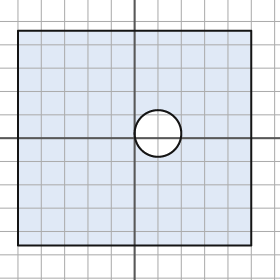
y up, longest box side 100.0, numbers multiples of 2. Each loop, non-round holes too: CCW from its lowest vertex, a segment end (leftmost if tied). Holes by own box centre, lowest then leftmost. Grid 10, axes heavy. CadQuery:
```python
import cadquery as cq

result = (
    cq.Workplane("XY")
    .moveTo(-50.0, -46.0)
    .lineTo(50.0, -46.0)
    .lineTo(50.0, 46.0)
    .lineTo(-50.0, 46.0)
    .close()
    .moveTo(10.0, 2.0)
    .circle(10.0)
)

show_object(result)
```